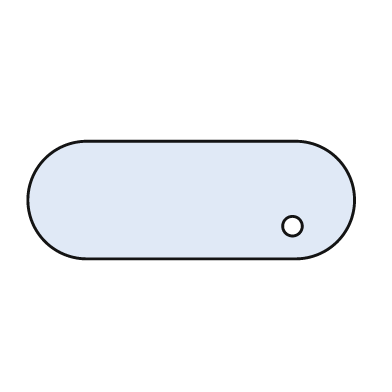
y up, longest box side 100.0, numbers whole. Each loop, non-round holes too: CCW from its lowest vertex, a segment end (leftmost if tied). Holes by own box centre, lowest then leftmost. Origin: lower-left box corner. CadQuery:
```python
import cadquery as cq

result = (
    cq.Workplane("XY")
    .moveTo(18.0, 0.0)
    .lineTo(82.0, 0.0)
    .threePointArc((100.0, 18.0), (82.0, 36.0))
    .lineTo(18.0, 36.0)
    .threePointArc((0.0, 18.0), (18.0, 0.0))
    .close()
    .moveTo(81.0, 10.0)
    .circle(3.0)
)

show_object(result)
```